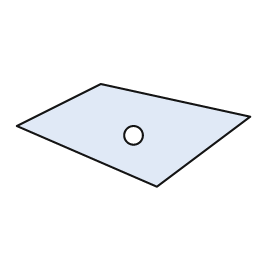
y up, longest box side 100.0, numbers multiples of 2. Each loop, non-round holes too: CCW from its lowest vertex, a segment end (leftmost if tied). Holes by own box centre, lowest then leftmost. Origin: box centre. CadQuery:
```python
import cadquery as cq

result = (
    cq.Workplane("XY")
    .moveTo(10.0, -22.0)
    .lineTo(50.0, 8.0)
    .lineTo(-14.0, 22.0)
    .lineTo(-50.0, 4.0)
    .close()
    .moveTo(0.0, 0.0)
    .circle(4.0)
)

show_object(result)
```